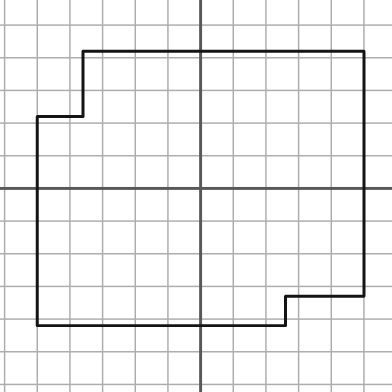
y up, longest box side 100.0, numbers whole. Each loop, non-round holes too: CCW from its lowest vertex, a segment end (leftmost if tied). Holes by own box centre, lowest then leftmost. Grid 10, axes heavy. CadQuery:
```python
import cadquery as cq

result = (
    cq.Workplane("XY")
    .moveTo(-50.0, -42.0)
    .lineTo(26.0, -42.0)
    .lineTo(26.0, -33.0)
    .lineTo(50.0, -33.0)
    .lineTo(50.0, 42.0)
    .lineTo(-36.0, 42.0)
    .lineTo(-36.0, 22.0)
    .lineTo(-50.0, 22.0)
    .close()
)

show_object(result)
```